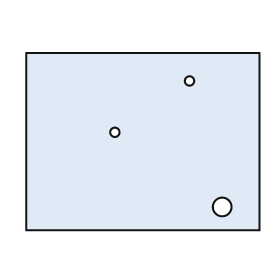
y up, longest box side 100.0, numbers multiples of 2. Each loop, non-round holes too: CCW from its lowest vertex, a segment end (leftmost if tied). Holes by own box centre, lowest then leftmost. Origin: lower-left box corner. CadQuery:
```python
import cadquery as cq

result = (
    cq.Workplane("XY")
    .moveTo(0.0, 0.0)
    .lineTo(100.0, 0.0)
    .lineTo(100.0, 76.0)
    .lineTo(0.0, 76.0)
    .close()
    .moveTo(84.0, 10.0)
    .circle(4.0)
    .moveTo(38.0, 42.0)
    .circle(2.0)
    .moveTo(70.0, 64.0)
    .circle(2.0)
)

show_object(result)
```